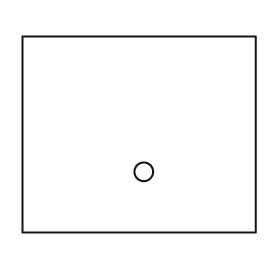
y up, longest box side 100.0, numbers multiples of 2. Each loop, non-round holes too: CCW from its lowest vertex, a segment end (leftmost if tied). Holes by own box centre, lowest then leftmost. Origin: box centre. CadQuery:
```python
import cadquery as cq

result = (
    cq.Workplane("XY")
    .moveTo(-50.0, -42.0)
    .lineTo(50.0, -42.0)
    .lineTo(50.0, 42.0)
    .lineTo(-50.0, 42.0)
    .close()
    .moveTo(2.0, -16.0)
    .circle(4.0)
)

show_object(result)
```